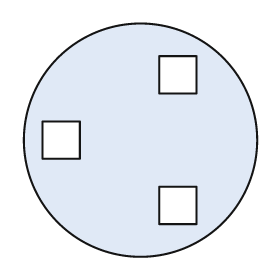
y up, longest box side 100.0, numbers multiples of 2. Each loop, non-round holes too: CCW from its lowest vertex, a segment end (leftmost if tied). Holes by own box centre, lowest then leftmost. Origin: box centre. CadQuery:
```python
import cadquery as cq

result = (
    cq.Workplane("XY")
    .moveTo(0.0, 0.0)
    .circle(50.0)
    .moveTo(8.0, -36.0)
    .lineTo(24.0, -36.0)
    .lineTo(24.0, -20.0)
    .lineTo(8.0, -20.0)
    .close()
    .moveTo(-42.0, -8.0)
    .lineTo(-26.0, -8.0)
    .lineTo(-26.0, 8.0)
    .lineTo(-42.0, 8.0)
    .close()
    .moveTo(8.0, 20.0)
    .lineTo(24.0, 20.0)
    .lineTo(24.0, 36.0)
    .lineTo(8.0, 36.0)
    .close()
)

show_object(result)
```